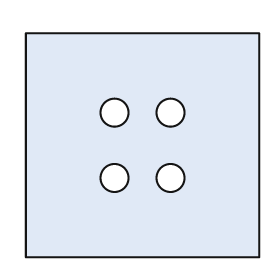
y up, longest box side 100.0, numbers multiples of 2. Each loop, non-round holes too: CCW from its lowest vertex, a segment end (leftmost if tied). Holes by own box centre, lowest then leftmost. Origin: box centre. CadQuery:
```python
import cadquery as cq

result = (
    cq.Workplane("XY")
    .moveTo(-50.0, -48.0)
    .lineTo(50.0, -48.0)
    .lineTo(50.0, 48.0)
    .lineTo(-50.0, 48.0)
    .close()
    .moveTo(-12.0, -14.0)
    .circle(6.0)
    .moveTo(12.0, -14.0)
    .circle(6.0)
    .moveTo(-12.0, 14.0)
    .circle(6.0)
    .moveTo(12.0, 14.0)
    .circle(6.0)
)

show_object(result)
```